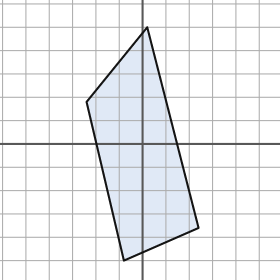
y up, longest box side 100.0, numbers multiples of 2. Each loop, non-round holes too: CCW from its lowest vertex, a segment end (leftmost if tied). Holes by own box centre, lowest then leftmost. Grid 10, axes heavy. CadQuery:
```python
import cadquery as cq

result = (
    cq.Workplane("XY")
    .moveTo(-8.0, -50.0)
    .lineTo(24.0, -36.0)
    .lineTo(2.0, 50.0)
    .lineTo(-24.0, 18.0)
    .close()
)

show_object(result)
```